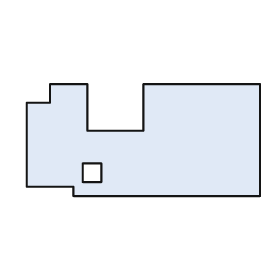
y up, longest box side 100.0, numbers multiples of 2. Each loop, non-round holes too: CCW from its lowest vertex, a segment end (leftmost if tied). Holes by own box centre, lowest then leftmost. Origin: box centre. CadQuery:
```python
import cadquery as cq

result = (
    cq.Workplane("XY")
    .moveTo(-30.0, -24.0)
    .lineTo(50.0, -24.0)
    .lineTo(50.0, 24.0)
    .lineTo(0.0, 24.0)
    .lineTo(0.0, 4.0)
    .lineTo(-24.0, 4.0)
    .lineTo(-24.0, 24.0)
    .lineTo(-40.0, 24.0)
    .lineTo(-40.0, 16.0)
    .lineTo(-50.0, 16.0)
    .lineTo(-50.0, -20.0)
    .lineTo(-30.0, -20.0)
    .close()
    .moveTo(-26.0, -18.0)
    .lineTo(-18.0, -18.0)
    .lineTo(-18.0, -10.0)
    .lineTo(-26.0, -10.0)
    .close()
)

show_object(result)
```